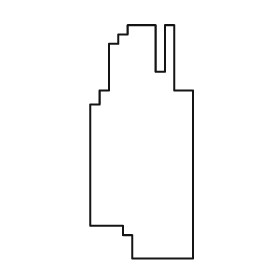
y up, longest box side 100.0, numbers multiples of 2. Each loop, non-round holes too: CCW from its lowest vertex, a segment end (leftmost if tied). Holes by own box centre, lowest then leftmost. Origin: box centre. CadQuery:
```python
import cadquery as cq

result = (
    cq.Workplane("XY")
    .moveTo(-4.0, -50.0)
    .lineTo(22.0, -50.0)
    .lineTo(22.0, 22.0)
    .lineTo(14.0, 22.0)
    .lineTo(14.0, 50.0)
    .lineTo(10.0, 50.0)
    .lineTo(10.0, 30.0)
    .lineTo(6.0, 30.0)
    .lineTo(6.0, 50.0)
    .lineTo(-6.0, 50.0)
    .lineTo(-6.0, 46.0)
    .lineTo(-10.0, 46.0)
    .lineTo(-10.0, 42.0)
    .lineTo(-14.0, 42.0)
    .lineTo(-14.0, 22.0)
    .lineTo(-18.0, 22.0)
    .lineTo(-18.0, 16.0)
    .lineTo(-22.0, 16.0)
    .lineTo(-22.0, -36.0)
    .lineTo(-8.0, -36.0)
    .lineTo(-8.0, -40.0)
    .lineTo(-4.0, -40.0)
    .close()
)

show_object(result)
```